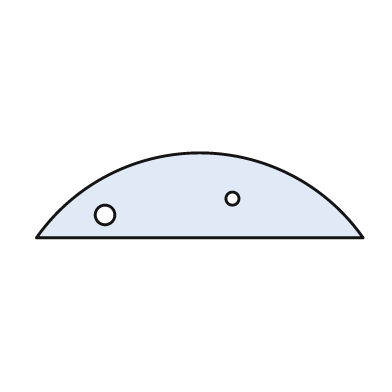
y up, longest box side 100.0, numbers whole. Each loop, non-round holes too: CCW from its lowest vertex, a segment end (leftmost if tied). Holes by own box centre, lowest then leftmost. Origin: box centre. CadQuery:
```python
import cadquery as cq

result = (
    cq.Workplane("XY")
    .moveTo(-50.0, -13.0)
    .lineTo(50.0, -13.0)
    .threePointArc((0.0, 13.0), (-50.0, -13.0))
    .close()
    .moveTo(-29.0, -6.0)
    .circle(3.0)
    .moveTo(10.0, -1.0)
    .circle(2.0)
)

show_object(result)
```